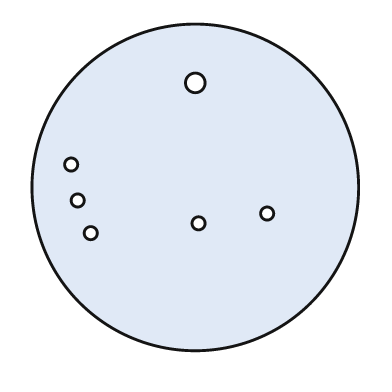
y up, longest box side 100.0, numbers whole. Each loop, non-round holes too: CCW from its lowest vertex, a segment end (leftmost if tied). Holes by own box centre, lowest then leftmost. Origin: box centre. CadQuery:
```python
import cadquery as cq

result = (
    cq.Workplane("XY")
    .moveTo(0.0, 0.0)
    .circle(50.0)
    .moveTo(-32.0, -14.0)
    .circle(2.0)
    .moveTo(1.0, -11.0)
    .circle(2.0)
    .moveTo(22.0, -8.0)
    .circle(2.0)
    .moveTo(-36.0, -4.0)
    .circle(2.0)
    .moveTo(-38.0, 7.0)
    .circle(2.0)
    .moveTo(0.0, 32.0)
    .circle(3.0)
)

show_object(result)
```